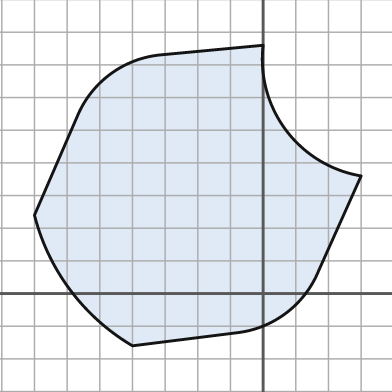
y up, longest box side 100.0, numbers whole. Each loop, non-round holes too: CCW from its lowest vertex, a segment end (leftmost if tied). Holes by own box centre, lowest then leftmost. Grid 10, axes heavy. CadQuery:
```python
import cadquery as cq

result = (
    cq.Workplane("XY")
    .moveTo(-40.0, -16.0)
    .lineTo(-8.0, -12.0)
    .threePointArc((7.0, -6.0), (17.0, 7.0))
    .lineTo(30.0, 36.0)
    .threePointArc((7.0, 50.0), (0.0, 76.0))
    .lineTo(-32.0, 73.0)
    .threePointArc((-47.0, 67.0), (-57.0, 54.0))
    .lineTo(-70.0, 24.0)
    .threePointArc((-59.0, 1.0), (-40.0, -16.0))
    .close()
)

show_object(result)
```